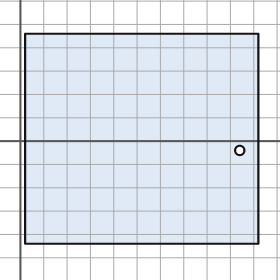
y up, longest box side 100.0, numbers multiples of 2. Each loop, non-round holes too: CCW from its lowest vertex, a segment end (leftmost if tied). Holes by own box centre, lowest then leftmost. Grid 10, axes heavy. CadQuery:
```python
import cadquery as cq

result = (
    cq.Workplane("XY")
    .moveTo(2.0, -44.0)
    .lineTo(102.0, -44.0)
    .lineTo(102.0, 46.0)
    .lineTo(2.0, 46.0)
    .close()
    .moveTo(94.0, -4.0)
    .circle(2.0)
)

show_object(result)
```